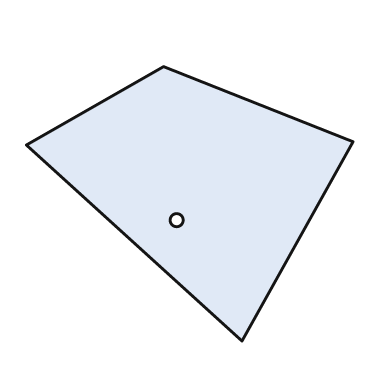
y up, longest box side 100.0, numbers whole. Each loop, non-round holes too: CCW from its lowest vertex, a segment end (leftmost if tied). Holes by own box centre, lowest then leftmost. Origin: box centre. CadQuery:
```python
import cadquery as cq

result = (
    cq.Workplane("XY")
    .moveTo(16.0, -42.0)
    .lineTo(50.0, 19.0)
    .lineTo(-8.0, 42.0)
    .lineTo(-50.0, 18.0)
    .close()
    .moveTo(-4.0, -5.0)
    .circle(2.0)
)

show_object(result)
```